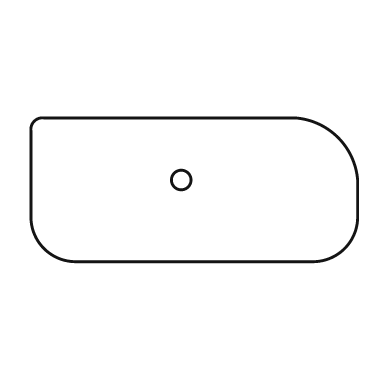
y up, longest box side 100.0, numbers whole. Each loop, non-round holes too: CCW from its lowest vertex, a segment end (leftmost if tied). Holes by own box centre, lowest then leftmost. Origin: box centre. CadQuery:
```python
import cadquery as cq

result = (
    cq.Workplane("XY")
    .moveTo(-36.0, -22.0)
    .lineTo(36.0, -22.0)
    .threePointArc((46.0, -18.0), (50.0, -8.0))
    .lineTo(50.0, 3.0)
    .threePointArc((44.0, 16.0), (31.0, 22.0))
    .lineTo(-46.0, 22.0)
    .threePointArc((-49.0, 21.0), (-50.0, 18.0))
    .lineTo(-50.0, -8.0)
    .threePointArc((-46.0, -18.0), (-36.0, -22.0))
    .close()
    .moveTo(-4.0, 3.0)
    .circle(3.0)
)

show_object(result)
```